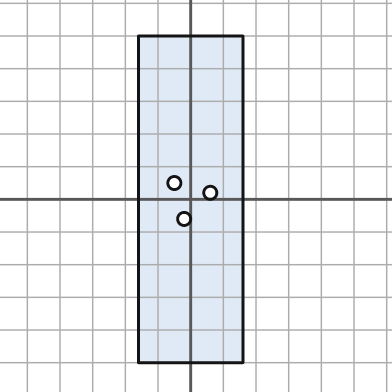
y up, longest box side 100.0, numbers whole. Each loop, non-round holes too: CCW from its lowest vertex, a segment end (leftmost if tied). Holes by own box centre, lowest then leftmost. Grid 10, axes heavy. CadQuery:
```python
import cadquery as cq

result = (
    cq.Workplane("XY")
    .moveTo(-16.0, -50.0)
    .lineTo(16.0, -50.0)
    .lineTo(16.0, 50.0)
    .lineTo(-16.0, 50.0)
    .close()
    .moveTo(-2.0, -6.0)
    .circle(2.0)
    .moveTo(6.0, 2.0)
    .circle(2.0)
    .moveTo(-5.0, 5.0)
    .circle(2.0)
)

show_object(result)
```